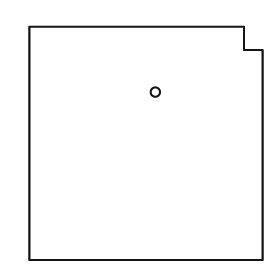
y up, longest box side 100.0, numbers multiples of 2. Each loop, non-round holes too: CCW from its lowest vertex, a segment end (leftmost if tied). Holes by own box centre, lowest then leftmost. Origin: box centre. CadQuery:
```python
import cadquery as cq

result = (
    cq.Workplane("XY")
    .moveTo(-50.0, -50.0)
    .lineTo(50.0, -50.0)
    .lineTo(50.0, 40.0)
    .lineTo(42.0, 40.0)
    .lineTo(42.0, 50.0)
    .lineTo(-50.0, 50.0)
    .close()
    .moveTo(4.0, 22.0)
    .circle(2.0)
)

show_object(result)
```